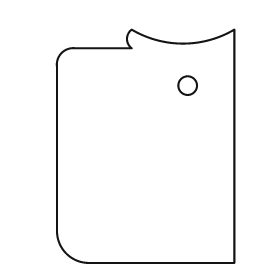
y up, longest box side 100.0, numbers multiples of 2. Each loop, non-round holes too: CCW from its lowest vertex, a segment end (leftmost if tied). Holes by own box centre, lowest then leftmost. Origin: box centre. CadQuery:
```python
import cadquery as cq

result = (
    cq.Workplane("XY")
    .moveTo(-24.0, -50.0)
    .lineTo(38.0, -50.0)
    .lineTo(38.0, 50.0)
    .threePointArc((16.0, 44.0), (-6.0, 50.0))
    .threePointArc((-8.0, 46.0), (-6.0, 42.0))
    .lineTo(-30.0, 42.0)
    .threePointArc((-36.0, 40.0), (-38.0, 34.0))
    .lineTo(-38.0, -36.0)
    .threePointArc((-34.0, -46.0), (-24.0, -50.0))
    .close()
    .moveTo(18.0, 26.0)
    .circle(4.0)
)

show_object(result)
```